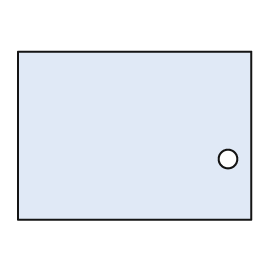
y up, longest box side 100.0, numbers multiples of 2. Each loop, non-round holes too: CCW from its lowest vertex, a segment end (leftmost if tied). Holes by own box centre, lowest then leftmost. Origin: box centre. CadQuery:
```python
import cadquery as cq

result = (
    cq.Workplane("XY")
    .moveTo(-50.0, -36.0)
    .lineTo(50.0, -36.0)
    .lineTo(50.0, 36.0)
    .lineTo(-50.0, 36.0)
    .close()
    .moveTo(40.0, -10.0)
    .circle(4.0)
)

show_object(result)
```